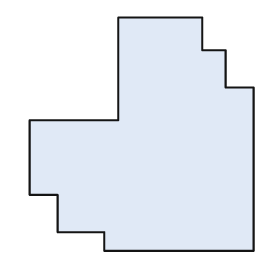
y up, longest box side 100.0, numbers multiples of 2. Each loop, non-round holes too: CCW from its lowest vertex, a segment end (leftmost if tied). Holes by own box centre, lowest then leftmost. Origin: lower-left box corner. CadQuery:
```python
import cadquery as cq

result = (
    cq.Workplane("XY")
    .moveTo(32.0, 0.0)
    .lineTo(96.0, 0.0)
    .lineTo(96.0, 70.0)
    .lineTo(84.0, 70.0)
    .lineTo(84.0, 86.0)
    .lineTo(74.0, 86.0)
    .lineTo(74.0, 100.0)
    .lineTo(38.0, 100.0)
    .lineTo(38.0, 56.0)
    .lineTo(0.0, 56.0)
    .lineTo(0.0, 24.0)
    .lineTo(12.0, 24.0)
    .lineTo(12.0, 8.0)
    .lineTo(32.0, 8.0)
    .close()
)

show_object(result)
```